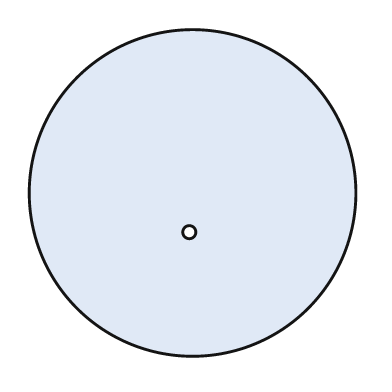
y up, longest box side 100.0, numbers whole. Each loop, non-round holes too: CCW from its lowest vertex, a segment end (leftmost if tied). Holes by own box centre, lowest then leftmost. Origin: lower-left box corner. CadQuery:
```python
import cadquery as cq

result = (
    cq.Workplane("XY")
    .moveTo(50.0, 50.0)
    .circle(50.0)
    .moveTo(49.0, 38.0)
    .circle(2.0)
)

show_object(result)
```